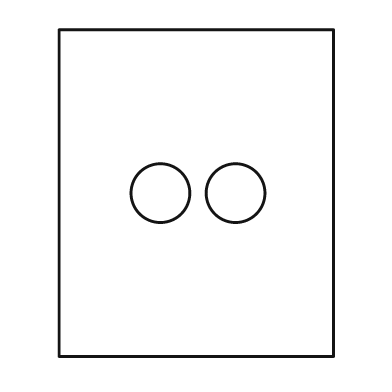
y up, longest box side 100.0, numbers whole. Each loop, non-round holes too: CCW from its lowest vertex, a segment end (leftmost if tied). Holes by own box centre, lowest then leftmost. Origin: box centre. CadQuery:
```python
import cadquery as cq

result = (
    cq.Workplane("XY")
    .moveTo(-42.0, -50.0)
    .lineTo(42.0, -50.0)
    .lineTo(42.0, 50.0)
    .lineTo(-42.0, 50.0)
    .close()
    .moveTo(-11.0, 0.0)
    .circle(9.0)
    .moveTo(12.0, 0.0)
    .circle(9.0)
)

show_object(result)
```